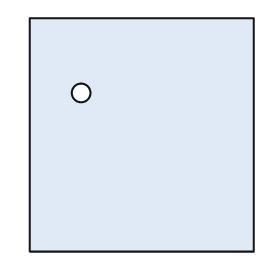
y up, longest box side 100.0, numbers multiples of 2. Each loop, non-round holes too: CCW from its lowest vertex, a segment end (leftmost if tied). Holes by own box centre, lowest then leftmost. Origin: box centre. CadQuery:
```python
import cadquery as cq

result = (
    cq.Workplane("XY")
    .moveTo(-48.0, -50.0)
    .lineTo(48.0, -50.0)
    .lineTo(48.0, 50.0)
    .lineTo(-48.0, 50.0)
    .close()
    .moveTo(-26.0, 18.0)
    .circle(4.0)
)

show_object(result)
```